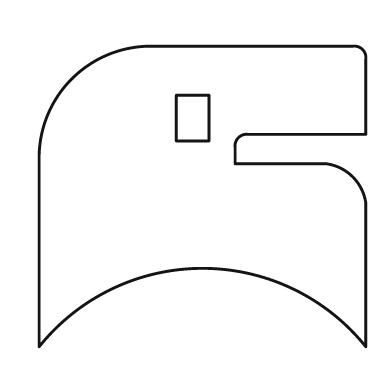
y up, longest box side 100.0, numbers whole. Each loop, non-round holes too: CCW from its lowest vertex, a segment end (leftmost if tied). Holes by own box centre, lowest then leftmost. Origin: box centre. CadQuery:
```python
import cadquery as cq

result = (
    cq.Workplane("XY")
    .moveTo(-50.0, -46.0)
    .threePointArc((0.0, -22.0), (50.0, -46.0))
    .lineTo(50.0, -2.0)
    .threePointArc((46.0, 6.0), (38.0, 10.0))
    .lineTo(10.0, 10.0)
    .lineTo(10.0, 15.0)
    .threePointArc((11.0, 18.0), (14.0, 19.0))
    .lineTo(50.0, 19.0)
    .lineTo(50.0, 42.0)
    .threePointArc((49.0, 45.0), (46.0, 46.0))
    .lineTo(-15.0, 46.0)
    .threePointArc((-40.0, 36.0), (-50.0, 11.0))
    .close()
    .moveTo(-8.0, 17.0)
    .lineTo(2.0, 17.0)
    .lineTo(2.0, 31.0)
    .lineTo(-8.0, 31.0)
    .close()
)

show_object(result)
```